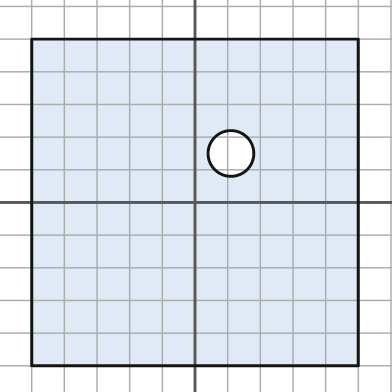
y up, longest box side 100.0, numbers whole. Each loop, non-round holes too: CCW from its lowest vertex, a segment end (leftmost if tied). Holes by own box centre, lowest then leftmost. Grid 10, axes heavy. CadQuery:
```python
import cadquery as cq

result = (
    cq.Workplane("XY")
    .moveTo(-50.0, -50.0)
    .lineTo(50.0, -50.0)
    .lineTo(50.0, 50.0)
    .lineTo(-50.0, 50.0)
    .close()
    .moveTo(11.0, 15.0)
    .circle(7.0)
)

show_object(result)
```